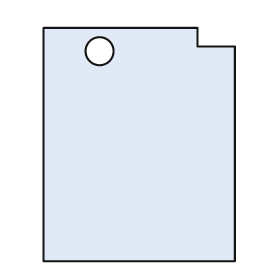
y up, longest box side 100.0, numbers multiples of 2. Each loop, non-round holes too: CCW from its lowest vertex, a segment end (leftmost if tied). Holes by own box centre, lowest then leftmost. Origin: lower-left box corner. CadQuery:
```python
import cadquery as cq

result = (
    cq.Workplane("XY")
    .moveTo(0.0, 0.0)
    .lineTo(82.0, 0.0)
    .lineTo(82.0, 92.0)
    .lineTo(66.0, 92.0)
    .lineTo(66.0, 100.0)
    .lineTo(0.0, 100.0)
    .close()
    .moveTo(24.0, 90.0)
    .circle(6.0)
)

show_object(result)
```